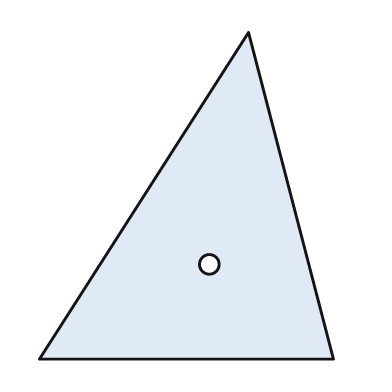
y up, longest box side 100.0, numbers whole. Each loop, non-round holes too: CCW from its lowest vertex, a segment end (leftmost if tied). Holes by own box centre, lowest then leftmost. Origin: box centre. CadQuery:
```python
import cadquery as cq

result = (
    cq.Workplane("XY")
    .moveTo(-45.0, -50.0)
    .lineTo(45.0, -50.0)
    .lineTo(19.0, 50.0)
    .close()
    .moveTo(7.0, -21.0)
    .circle(3.0)
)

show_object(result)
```